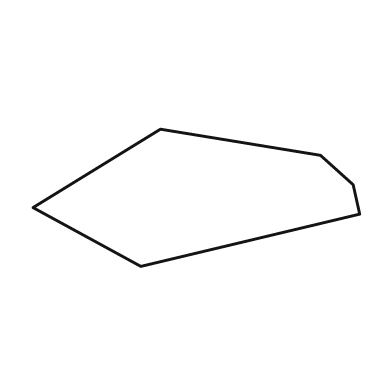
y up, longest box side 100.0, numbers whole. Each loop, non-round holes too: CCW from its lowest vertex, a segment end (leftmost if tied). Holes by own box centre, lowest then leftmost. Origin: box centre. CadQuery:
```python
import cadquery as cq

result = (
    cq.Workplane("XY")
    .moveTo(-17.0, -21.0)
    .lineTo(50.0, -5.0)
    .lineTo(48.0, 4.0)
    .lineTo(38.0, 13.0)
    .lineTo(-11.0, 21.0)
    .lineTo(-50.0, -3.0)
    .close()
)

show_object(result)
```